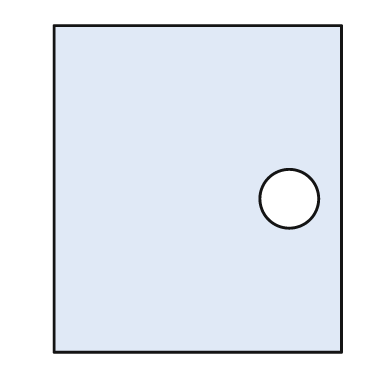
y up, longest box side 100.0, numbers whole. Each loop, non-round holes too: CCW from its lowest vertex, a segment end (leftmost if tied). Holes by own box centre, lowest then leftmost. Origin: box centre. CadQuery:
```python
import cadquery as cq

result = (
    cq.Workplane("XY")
    .moveTo(-44.0, -50.0)
    .lineTo(44.0, -50.0)
    .lineTo(44.0, 50.0)
    .lineTo(-44.0, 50.0)
    .close()
    .moveTo(28.0, -3.0)
    .circle(9.0)
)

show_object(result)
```